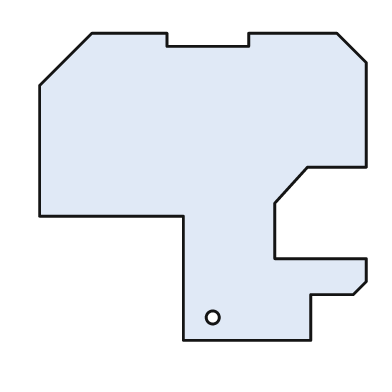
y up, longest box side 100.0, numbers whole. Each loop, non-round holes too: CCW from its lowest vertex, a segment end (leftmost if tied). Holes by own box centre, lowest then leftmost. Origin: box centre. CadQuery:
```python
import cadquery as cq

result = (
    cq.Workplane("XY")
    .moveTo(-6.0, -47.0)
    .lineTo(33.0, -47.0)
    .lineTo(33.0, -33.0)
    .lineTo(46.0, -33.0)
    .lineTo(50.0, -29.0)
    .lineTo(50.0, -22.0)
    .lineTo(22.0, -22.0)
    .lineTo(22.0, -5.0)
    .lineTo(32.0, 6.0)
    .lineTo(50.0, 6.0)
    .lineTo(50.0, 38.0)
    .lineTo(41.0, 47.0)
    .lineTo(14.0, 47.0)
    .lineTo(14.0, 43.0)
    .lineTo(-11.0, 43.0)
    .lineTo(-11.0, 47.0)
    .lineTo(-34.0, 47.0)
    .lineTo(-50.0, 31.0)
    .lineTo(-50.0, -9.0)
    .lineTo(-6.0, -9.0)
    .close()
    .moveTo(3.0, -40.0)
    .circle(2.0)
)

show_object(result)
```